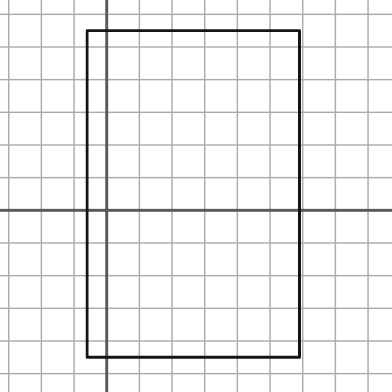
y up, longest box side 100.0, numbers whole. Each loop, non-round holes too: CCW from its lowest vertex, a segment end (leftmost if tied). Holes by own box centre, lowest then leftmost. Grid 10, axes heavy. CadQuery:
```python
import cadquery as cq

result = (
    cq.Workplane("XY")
    .moveTo(-6.0, -45.0)
    .lineTo(59.0, -45.0)
    .lineTo(59.0, 55.0)
    .lineTo(-6.0, 55.0)
    .close()
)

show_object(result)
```